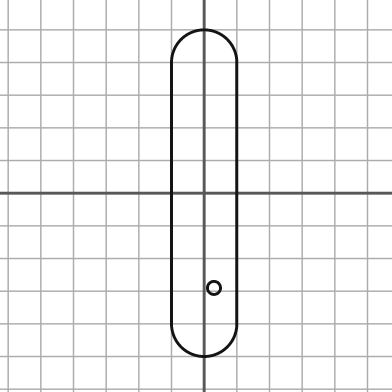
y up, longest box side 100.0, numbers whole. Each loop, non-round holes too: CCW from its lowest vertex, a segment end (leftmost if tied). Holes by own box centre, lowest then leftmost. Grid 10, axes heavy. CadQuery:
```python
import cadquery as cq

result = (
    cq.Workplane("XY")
    .moveTo(-10.0, -40.0)
    .threePointArc((0.0, -50.0), (10.0, -40.0))
    .lineTo(10.0, 40.0)
    .threePointArc((0.0, 50.0), (-10.0, 40.0))
    .close()
    .moveTo(3.0, -29.0)
    .circle(2.0)
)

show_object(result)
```